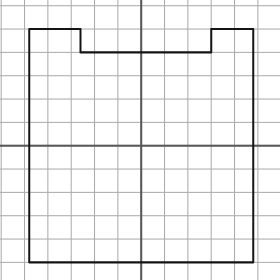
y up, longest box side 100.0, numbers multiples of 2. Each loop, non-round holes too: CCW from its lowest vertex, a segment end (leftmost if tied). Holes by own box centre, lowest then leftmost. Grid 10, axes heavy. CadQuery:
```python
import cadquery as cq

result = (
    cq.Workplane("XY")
    .moveTo(-48.0, -50.0)
    .lineTo(48.0, -50.0)
    .lineTo(48.0, 50.0)
    .lineTo(30.0, 50.0)
    .lineTo(30.0, 40.0)
    .lineTo(-26.0, 40.0)
    .lineTo(-26.0, 50.0)
    .lineTo(-48.0, 50.0)
    .close()
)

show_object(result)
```